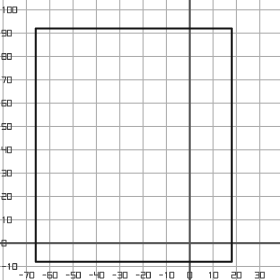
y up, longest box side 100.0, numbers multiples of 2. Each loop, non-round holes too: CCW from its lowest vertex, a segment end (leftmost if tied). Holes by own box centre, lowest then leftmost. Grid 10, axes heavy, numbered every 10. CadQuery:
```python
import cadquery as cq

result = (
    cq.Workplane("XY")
    .moveTo(-66.0, -8.0)
    .lineTo(18.0, -8.0)
    .lineTo(18.0, 92.0)
    .lineTo(-66.0, 92.0)
    .close()
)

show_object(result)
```